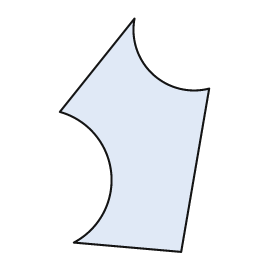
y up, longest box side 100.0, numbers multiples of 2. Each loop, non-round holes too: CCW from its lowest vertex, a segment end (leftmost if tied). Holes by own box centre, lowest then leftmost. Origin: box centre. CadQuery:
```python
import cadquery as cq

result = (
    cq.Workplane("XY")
    .moveTo(20.0, -50.0)
    .lineTo(32.0, 20.0)
    .threePointArc((8.0, 26.0), (0.0, 50.0))
    .lineTo(-32.0, 10.0)
    .threePointArc((-10.0, -16.0), (-26.0, -46.0))
    .close()
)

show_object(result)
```